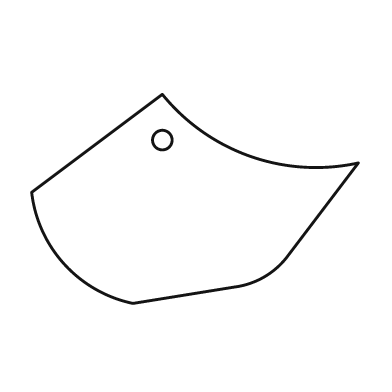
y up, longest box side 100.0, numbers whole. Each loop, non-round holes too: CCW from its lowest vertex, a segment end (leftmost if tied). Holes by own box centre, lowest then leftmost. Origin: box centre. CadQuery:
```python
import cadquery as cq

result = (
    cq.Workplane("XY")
    .moveTo(-19.0, -32.0)
    .lineTo(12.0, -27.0)
    .threePointArc((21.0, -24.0), (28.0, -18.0))
    .lineTo(50.0, 11.0)
    .threePointArc((17.0, 13.0), (-10.0, 32.0))
    .lineTo(-50.0, 2.0)
    .threePointArc((-40.0, -20.0), (-19.0, -32.0))
    .close()
    .moveTo(-10.0, 18.0)
    .circle(3.0)
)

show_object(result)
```